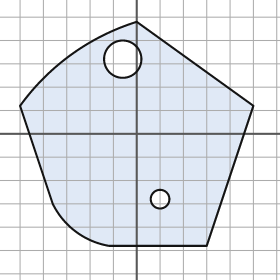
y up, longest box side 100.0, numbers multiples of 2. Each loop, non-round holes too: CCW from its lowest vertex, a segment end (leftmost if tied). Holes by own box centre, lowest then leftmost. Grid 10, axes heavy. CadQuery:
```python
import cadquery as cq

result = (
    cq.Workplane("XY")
    .moveTo(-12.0, -48.0)
    .lineTo(30.0, -48.0)
    .lineTo(50.0, 12.0)
    .lineTo(0.0, 48.0)
    .threePointArc((-28.0, 34.0), (-50.0, 12.0))
    .lineTo(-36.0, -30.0)
    .threePointArc((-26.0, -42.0), (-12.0, -48.0))
    .close()
    .moveTo(10.0, -28.0)
    .circle(4.0)
    .moveTo(-6.0, 32.0)
    .circle(8.0)
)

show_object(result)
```